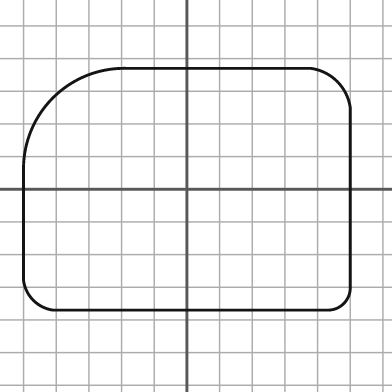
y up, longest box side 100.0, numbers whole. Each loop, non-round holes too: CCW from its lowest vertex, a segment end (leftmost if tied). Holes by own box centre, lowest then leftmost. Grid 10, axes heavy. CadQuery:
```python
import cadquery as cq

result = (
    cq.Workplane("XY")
    .moveTo(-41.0, -37.0)
    .lineTo(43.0, -37.0)
    .threePointArc((48.0, -35.0), (50.0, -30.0))
    .lineTo(50.0, 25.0)
    .threePointArc((46.0, 33.0), (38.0, 37.0))
    .lineTo(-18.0, 37.0)
    .threePointArc((-41.0, 28.0), (-50.0, 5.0))
    .lineTo(-50.0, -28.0)
    .threePointArc((-47.0, -34.0), (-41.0, -37.0))
    .close()
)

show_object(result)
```